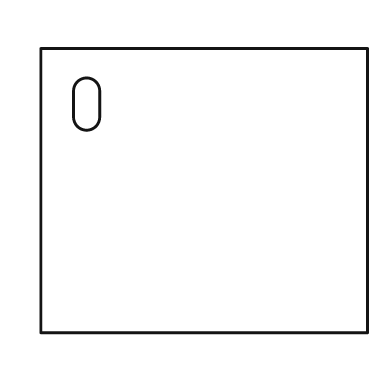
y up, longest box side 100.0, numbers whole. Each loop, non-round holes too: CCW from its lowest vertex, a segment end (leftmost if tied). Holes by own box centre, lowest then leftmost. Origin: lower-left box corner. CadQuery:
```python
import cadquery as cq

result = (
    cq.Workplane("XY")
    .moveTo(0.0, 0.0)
    .lineTo(100.0, 0.0)
    .lineTo(100.0, 87.0)
    .lineTo(0.0, 87.0)
    .close()
    .moveTo(10.0, 66.0)
    .threePointArc((14.0, 62.0), (18.0, 66.0))
    .lineTo(18.0, 74.0)
    .threePointArc((14.0, 78.0), (10.0, 74.0))
    .close()
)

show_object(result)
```